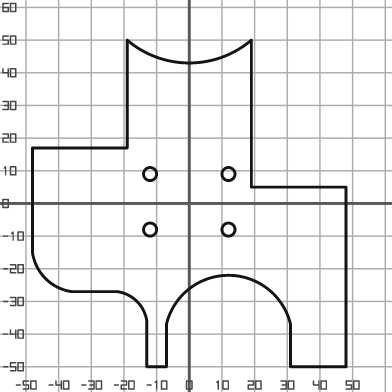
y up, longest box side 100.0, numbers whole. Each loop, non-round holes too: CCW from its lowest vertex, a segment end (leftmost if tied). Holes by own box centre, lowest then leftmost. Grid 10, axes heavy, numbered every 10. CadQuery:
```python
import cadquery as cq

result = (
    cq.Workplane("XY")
    .moveTo(-13.0, -50.0)
    .lineTo(-7.0, -50.0)
    .lineTo(-7.0, -37.0)
    .threePointArc((12.0, -22.0), (31.0, -37.0))
    .lineTo(31.0, -50.0)
    .lineTo(48.0, -50.0)
    .lineTo(48.0, 5.0)
    .lineTo(19.0, 5.0)
    .lineTo(19.0, 50.0)
    .threePointArc((0.0, 43.0), (-19.0, 50.0))
    .lineTo(-19.0, 17.0)
    .lineTo(-48.0, 17.0)
    .lineTo(-48.0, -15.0)
    .threePointArc((-44.0, -23.0), (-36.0, -27.0))
    .lineTo(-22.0, -27.0)
    .threePointArc((-16.0, -30.0), (-13.0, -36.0))
    .close()
    .moveTo(-12.0, -8.0)
    .circle(2.0)
    .moveTo(12.0, -8.0)
    .circle(2.0)
    .moveTo(-12.0, 9.0)
    .circle(2.0)
    .moveTo(12.0, 9.0)
    .circle(2.0)
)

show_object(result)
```